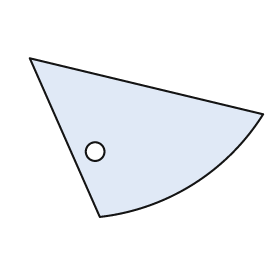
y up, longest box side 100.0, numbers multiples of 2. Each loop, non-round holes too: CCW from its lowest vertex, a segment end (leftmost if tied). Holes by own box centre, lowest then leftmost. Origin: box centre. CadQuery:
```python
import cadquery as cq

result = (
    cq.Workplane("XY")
    .moveTo(-20.0, -34.0)
    .threePointArc((20.0, -20.0), (50.0, 10.0))
    .lineTo(-50.0, 34.0)
    .close()
    .moveTo(-22.0, -6.0)
    .circle(4.0)
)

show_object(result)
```